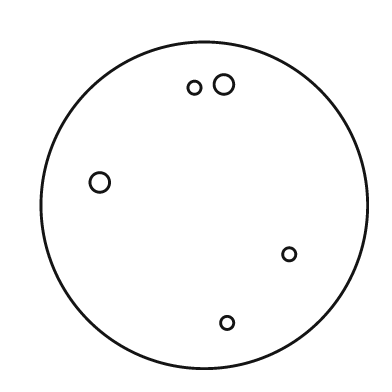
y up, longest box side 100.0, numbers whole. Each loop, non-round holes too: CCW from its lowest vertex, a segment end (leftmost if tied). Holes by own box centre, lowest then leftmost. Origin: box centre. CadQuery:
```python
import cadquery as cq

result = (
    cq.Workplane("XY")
    .moveTo(0.0, 0.0)
    .circle(50.0)
    .moveTo(7.0, -36.0)
    .circle(2.0)
    .moveTo(26.0, -15.0)
    .circle(2.0)
    .moveTo(-32.0, 7.0)
    .circle(3.0)
    .moveTo(-3.0, 36.0)
    .circle(2.0)
    .moveTo(6.0, 37.0)
    .circle(3.0)
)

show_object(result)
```